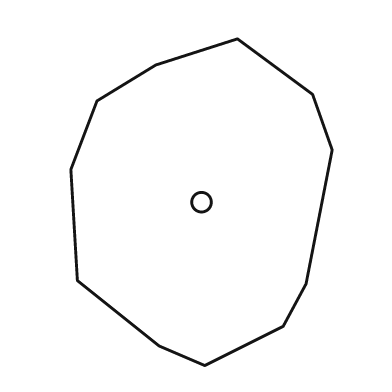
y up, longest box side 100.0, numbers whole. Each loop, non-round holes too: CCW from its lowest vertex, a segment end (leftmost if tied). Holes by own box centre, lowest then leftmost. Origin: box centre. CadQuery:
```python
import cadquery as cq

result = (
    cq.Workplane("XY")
    .moveTo(1.0, -50.0)
    .lineTo(25.0, -38.0)
    .lineTo(32.0, -25.0)
    .lineTo(40.0, 16.0)
    .lineTo(34.0, 33.0)
    .lineTo(11.0, 50.0)
    .lineTo(-14.0, 42.0)
    .lineTo(-32.0, 31.0)
    .lineTo(-40.0, 10.0)
    .lineTo(-38.0, -24.0)
    .lineTo(-13.0, -44.0)
    .close()
    .moveTo(0.0, 0.0)
    .circle(3.0)
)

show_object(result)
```